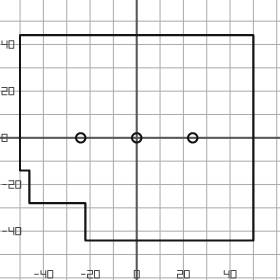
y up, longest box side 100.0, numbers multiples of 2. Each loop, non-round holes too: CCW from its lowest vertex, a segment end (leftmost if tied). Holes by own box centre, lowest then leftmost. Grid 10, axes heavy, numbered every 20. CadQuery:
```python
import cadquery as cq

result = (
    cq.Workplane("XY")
    .moveTo(-22.0, -44.0)
    .lineTo(50.0, -44.0)
    .lineTo(50.0, 44.0)
    .lineTo(-50.0, 44.0)
    .lineTo(-50.0, -14.0)
    .lineTo(-46.0, -14.0)
    .lineTo(-46.0, -28.0)
    .lineTo(-22.0, -28.0)
    .close()
    .moveTo(-24.0, 0.0)
    .circle(2.0)
    .moveTo(0.0, 0.0)
    .circle(2.0)
    .moveTo(24.0, 0.0)
    .circle(2.0)
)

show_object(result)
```